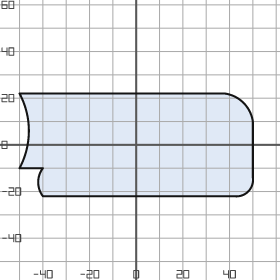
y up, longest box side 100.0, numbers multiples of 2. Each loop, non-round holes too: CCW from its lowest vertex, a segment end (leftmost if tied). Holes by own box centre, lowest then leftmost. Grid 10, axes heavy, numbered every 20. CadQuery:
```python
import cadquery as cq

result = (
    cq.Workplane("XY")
    .moveTo(-40.0, -22.0)
    .lineTo(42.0, -22.0)
    .threePointArc((48.0, -20.0), (50.0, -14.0))
    .lineTo(50.0, 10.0)
    .threePointArc((46.0, 18.0), (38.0, 22.0))
    .lineTo(-50.0, 22.0)
    .threePointArc((-46.0, 6.0), (-50.0, -10.0))
    .lineTo(-40.0, -10.0)
    .threePointArc((-42.0, -16.0), (-40.0, -22.0))
    .close()
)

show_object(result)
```